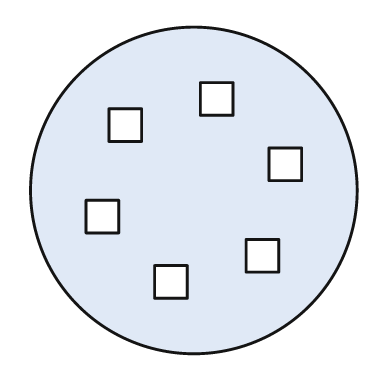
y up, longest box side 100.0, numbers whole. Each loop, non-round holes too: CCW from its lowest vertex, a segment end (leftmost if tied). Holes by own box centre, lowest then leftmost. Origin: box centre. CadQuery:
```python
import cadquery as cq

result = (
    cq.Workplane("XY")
    .moveTo(0.0, 0.0)
    .circle(50.0)
    .moveTo(-12.0, -33.0)
    .lineTo(-2.0, -33.0)
    .lineTo(-2.0, -23.0)
    .lineTo(-12.0, -23.0)
    .close()
    .moveTo(16.0, -25.0)
    .lineTo(26.0, -25.0)
    .lineTo(26.0, -15.0)
    .lineTo(16.0, -15.0)
    .close()
    .moveTo(-33.0, -13.0)
    .lineTo(-23.0, -13.0)
    .lineTo(-23.0, -3.0)
    .lineTo(-33.0, -3.0)
    .close()
    .moveTo(23.0, 3.0)
    .lineTo(33.0, 3.0)
    .lineTo(33.0, 13.0)
    .lineTo(23.0, 13.0)
    .close()
    .moveTo(-26.0, 15.0)
    .lineTo(-16.0, 15.0)
    .lineTo(-16.0, 25.0)
    .lineTo(-26.0, 25.0)
    .close()
    .moveTo(2.0, 23.0)
    .lineTo(12.0, 23.0)
    .lineTo(12.0, 33.0)
    .lineTo(2.0, 33.0)
    .close()
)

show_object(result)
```